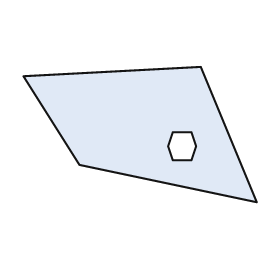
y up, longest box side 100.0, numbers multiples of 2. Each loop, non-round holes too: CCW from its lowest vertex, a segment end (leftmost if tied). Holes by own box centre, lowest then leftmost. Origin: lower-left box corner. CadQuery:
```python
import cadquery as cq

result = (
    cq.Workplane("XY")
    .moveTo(100.0, 0.0)
    .lineTo(76.0, 58.0)
    .lineTo(0.0, 54.0)
    .lineTo(24.0, 16.0)
    .close()
    .moveTo(64.0, 18.0)
    .lineTo(72.0, 18.0)
    .lineTo(74.0, 24.0)
    .lineTo(72.0, 30.0)
    .lineTo(64.0, 30.0)
    .lineTo(62.0, 24.0)
    .close()
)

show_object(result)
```